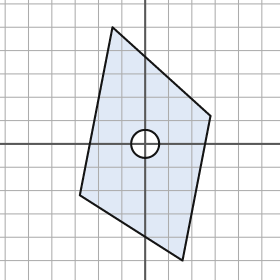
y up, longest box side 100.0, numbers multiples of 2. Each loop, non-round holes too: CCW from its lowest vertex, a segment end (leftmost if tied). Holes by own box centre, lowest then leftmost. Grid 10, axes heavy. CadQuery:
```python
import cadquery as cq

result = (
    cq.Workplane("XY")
    .moveTo(16.0, -50.0)
    .lineTo(28.0, 12.0)
    .lineTo(-14.0, 50.0)
    .lineTo(-28.0, -22.0)
    .close()
    .moveTo(0.0, 0.0)
    .circle(6.0)
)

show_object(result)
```